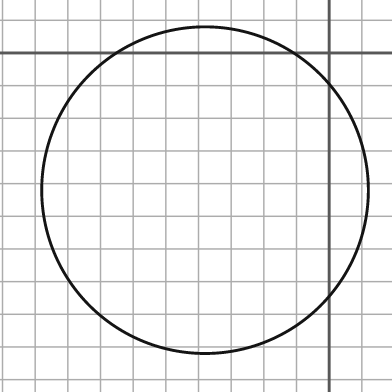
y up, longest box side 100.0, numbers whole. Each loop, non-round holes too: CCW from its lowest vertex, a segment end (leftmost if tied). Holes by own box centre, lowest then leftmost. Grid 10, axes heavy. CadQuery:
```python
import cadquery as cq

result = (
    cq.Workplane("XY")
    .moveTo(-38.0, -42.0)
    .circle(50.0)
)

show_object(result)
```